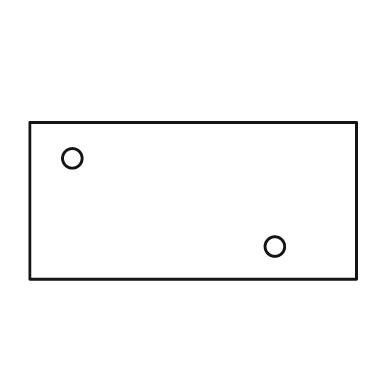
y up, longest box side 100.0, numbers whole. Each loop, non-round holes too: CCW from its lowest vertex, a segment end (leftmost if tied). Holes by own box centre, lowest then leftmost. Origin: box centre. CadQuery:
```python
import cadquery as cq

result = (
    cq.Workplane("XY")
    .moveTo(-50.0, -24.0)
    .lineTo(50.0, -24.0)
    .lineTo(50.0, 24.0)
    .lineTo(-50.0, 24.0)
    .close()
    .moveTo(25.0, -14.0)
    .circle(3.0)
    .moveTo(-37.0, 13.0)
    .circle(3.0)
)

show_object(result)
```